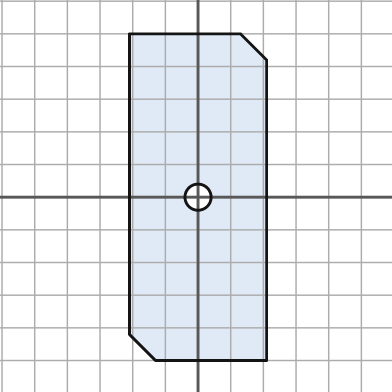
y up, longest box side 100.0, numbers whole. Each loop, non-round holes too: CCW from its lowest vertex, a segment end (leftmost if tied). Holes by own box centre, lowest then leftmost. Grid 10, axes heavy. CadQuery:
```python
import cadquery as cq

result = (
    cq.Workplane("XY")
    .moveTo(-13.0, -50.0)
    .lineTo(21.0, -50.0)
    .lineTo(21.0, 42.0)
    .lineTo(13.0, 50.0)
    .lineTo(-21.0, 50.0)
    .lineTo(-21.0, -42.0)
    .close()
    .moveTo(0.0, 0.0)
    .circle(4.0)
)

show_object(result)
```